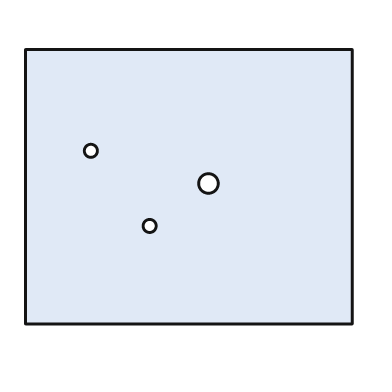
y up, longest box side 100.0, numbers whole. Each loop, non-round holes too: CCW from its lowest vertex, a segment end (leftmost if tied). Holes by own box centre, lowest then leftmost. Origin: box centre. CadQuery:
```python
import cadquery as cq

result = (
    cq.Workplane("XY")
    .moveTo(-50.0, -42.0)
    .lineTo(50.0, -42.0)
    .lineTo(50.0, 42.0)
    .lineTo(-50.0, 42.0)
    .close()
    .moveTo(-12.0, -12.0)
    .circle(2.0)
    .moveTo(6.0, 1.0)
    .circle(3.0)
    .moveTo(-30.0, 11.0)
    .circle(2.0)
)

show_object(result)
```